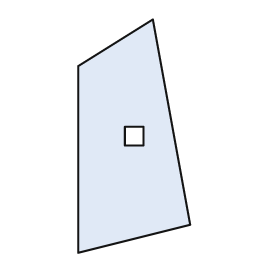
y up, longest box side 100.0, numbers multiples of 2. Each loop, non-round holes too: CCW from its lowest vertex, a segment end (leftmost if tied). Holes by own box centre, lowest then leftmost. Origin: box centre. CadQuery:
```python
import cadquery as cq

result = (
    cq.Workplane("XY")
    .moveTo(-24.0, -50.0)
    .lineTo(24.0, -38.0)
    .lineTo(8.0, 50.0)
    .lineTo(-24.0, 30.0)
    .close()
    .moveTo(-4.0, -4.0)
    .lineTo(4.0, -4.0)
    .lineTo(4.0, 4.0)
    .lineTo(-4.0, 4.0)
    .close()
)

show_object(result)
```